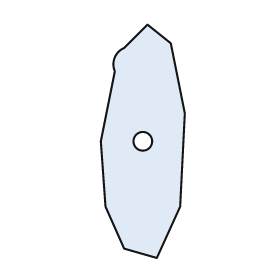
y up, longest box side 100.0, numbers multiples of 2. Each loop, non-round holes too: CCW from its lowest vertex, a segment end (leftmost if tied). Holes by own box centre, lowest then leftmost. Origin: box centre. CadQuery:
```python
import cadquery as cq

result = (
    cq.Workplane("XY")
    .moveTo(6.0, -50.0)
    .lineTo(16.0, -28.0)
    .lineTo(18.0, 12.0)
    .lineTo(12.0, 42.0)
    .lineTo(2.0, 50.0)
    .lineTo(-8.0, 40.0)
    .threePointArc((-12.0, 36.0), (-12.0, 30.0))
    .lineTo(-18.0, 0.0)
    .lineTo(-16.0, -28.0)
    .lineTo(-8.0, -46.0)
    .close()
    .moveTo(0.0, 0.0)
    .circle(4.0)
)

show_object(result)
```